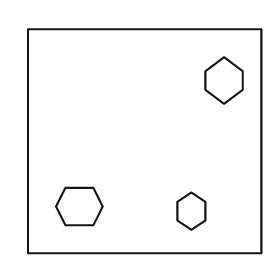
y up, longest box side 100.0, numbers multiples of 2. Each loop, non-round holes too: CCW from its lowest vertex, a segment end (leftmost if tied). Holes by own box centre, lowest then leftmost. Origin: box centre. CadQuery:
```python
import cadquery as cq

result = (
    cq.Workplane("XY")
    .moveTo(-50.0, -48.0)
    .lineTo(50.0, -48.0)
    .lineTo(50.0, 48.0)
    .lineTo(-50.0, 48.0)
    .close()
    .moveTo(20.0, -38.0)
    .lineTo(26.0, -34.0)
    .lineTo(26.0, -26.0)
    .lineTo(20.0, -22.0)
    .lineTo(14.0, -26.0)
    .lineTo(14.0, -34.0)
    .close()
    .moveTo(-34.0, -36.0)
    .lineTo(-22.0, -36.0)
    .lineTo(-18.0, -28.0)
    .lineTo(-22.0, -20.0)
    .lineTo(-34.0, -20.0)
    .lineTo(-38.0, -28.0)
    .close()
    .moveTo(34.0, 16.0)
    .lineTo(42.0, 22.0)
    .lineTo(42.0, 30.0)
    .lineTo(34.0, 36.0)
    .lineTo(26.0, 30.0)
    .lineTo(26.0, 22.0)
    .close()
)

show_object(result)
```